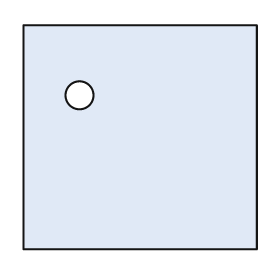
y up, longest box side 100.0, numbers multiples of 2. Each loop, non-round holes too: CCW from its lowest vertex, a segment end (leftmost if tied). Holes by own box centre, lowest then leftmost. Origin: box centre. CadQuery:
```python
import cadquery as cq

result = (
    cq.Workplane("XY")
    .moveTo(-50.0, -48.0)
    .lineTo(50.0, -48.0)
    .lineTo(50.0, 48.0)
    .lineTo(-50.0, 48.0)
    .close()
    .moveTo(-26.0, 18.0)
    .circle(6.0)
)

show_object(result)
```